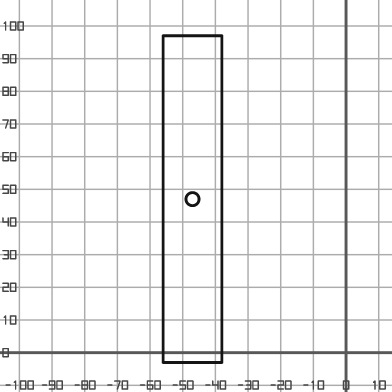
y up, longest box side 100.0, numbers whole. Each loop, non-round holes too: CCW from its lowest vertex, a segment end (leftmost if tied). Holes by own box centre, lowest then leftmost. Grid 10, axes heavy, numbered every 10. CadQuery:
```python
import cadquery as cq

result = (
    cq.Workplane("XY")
    .moveTo(-56.0, -3.0)
    .lineTo(-38.0, -3.0)
    .lineTo(-38.0, 97.0)
    .lineTo(-56.0, 97.0)
    .close()
    .moveTo(-47.0, 47.0)
    .circle(2.0)
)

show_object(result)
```